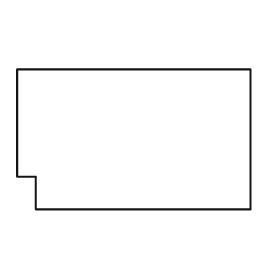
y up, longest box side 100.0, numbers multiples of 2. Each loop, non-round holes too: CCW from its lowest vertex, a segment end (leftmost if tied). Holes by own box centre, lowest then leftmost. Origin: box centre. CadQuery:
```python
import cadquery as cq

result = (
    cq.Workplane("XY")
    .moveTo(-42.0, -30.0)
    .lineTo(50.0, -30.0)
    .lineTo(50.0, 30.0)
    .lineTo(-50.0, 30.0)
    .lineTo(-50.0, -16.0)
    .lineTo(-42.0, -16.0)
    .close()
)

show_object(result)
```